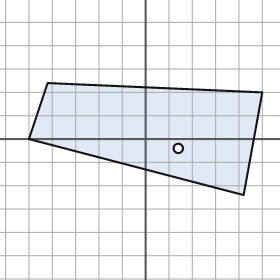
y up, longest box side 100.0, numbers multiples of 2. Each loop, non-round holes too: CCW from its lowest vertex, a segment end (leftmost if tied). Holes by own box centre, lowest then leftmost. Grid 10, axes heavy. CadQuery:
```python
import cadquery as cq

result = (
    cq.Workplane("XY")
    .moveTo(42.0, -24.0)
    .lineTo(50.0, 20.0)
    .lineTo(-42.0, 24.0)
    .lineTo(-50.0, 0.0)
    .close()
    .moveTo(14.0, -4.0)
    .circle(2.0)
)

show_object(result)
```